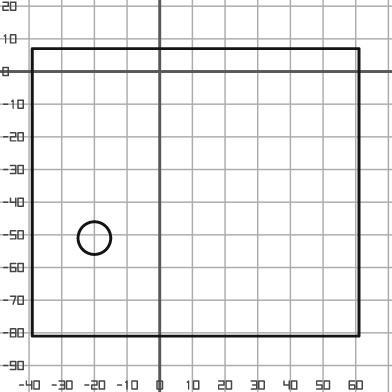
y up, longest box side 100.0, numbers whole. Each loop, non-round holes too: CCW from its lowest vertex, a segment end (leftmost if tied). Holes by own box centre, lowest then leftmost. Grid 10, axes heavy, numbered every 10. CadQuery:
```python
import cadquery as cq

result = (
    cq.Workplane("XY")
    .moveTo(-39.0, -81.0)
    .lineTo(61.0, -81.0)
    .lineTo(61.0, 7.0)
    .lineTo(-39.0, 7.0)
    .close()
    .moveTo(-20.0, -51.0)
    .circle(5.0)
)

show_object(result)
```